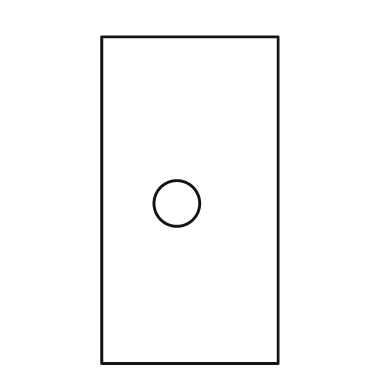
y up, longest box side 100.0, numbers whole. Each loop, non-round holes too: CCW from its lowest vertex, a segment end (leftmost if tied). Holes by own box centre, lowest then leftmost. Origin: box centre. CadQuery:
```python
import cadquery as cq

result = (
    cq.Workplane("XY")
    .moveTo(-27.0, -50.0)
    .lineTo(27.0, -50.0)
    .lineTo(27.0, 50.0)
    .lineTo(-27.0, 50.0)
    .close()
    .moveTo(-4.0, -1.0)
    .circle(7.0)
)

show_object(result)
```